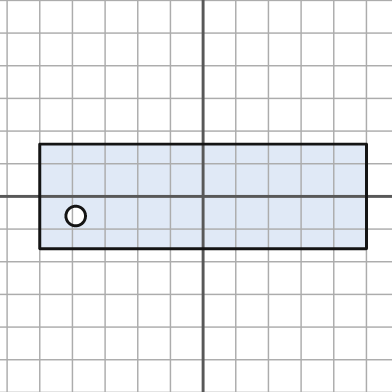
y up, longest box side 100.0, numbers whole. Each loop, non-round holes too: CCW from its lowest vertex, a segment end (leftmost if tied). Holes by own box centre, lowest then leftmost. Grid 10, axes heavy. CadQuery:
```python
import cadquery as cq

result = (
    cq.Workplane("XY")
    .moveTo(-50.0, -16.0)
    .lineTo(50.0, -16.0)
    .lineTo(50.0, 16.0)
    .lineTo(-50.0, 16.0)
    .close()
    .moveTo(-39.0, -6.0)
    .circle(3.0)
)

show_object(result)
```